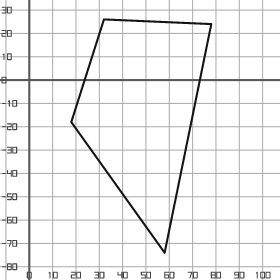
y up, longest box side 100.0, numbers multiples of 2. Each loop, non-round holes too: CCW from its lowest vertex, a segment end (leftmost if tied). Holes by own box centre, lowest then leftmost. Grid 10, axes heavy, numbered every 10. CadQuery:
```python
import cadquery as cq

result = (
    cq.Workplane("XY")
    .moveTo(58.0, -74.0)
    .lineTo(78.0, 24.0)
    .lineTo(32.0, 26.0)
    .lineTo(18.0, -18.0)
    .close()
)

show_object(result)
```